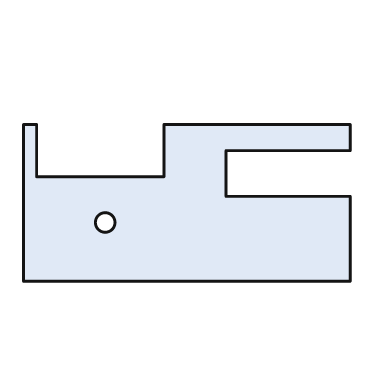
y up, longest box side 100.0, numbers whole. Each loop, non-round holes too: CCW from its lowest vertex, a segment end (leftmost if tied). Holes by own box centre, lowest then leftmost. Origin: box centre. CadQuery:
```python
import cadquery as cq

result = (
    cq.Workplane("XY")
    .moveTo(-50.0, -24.0)
    .lineTo(50.0, -24.0)
    .lineTo(50.0, 2.0)
    .lineTo(12.0, 2.0)
    .lineTo(12.0, 16.0)
    .lineTo(50.0, 16.0)
    .lineTo(50.0, 24.0)
    .lineTo(-7.0, 24.0)
    .lineTo(-7.0, 8.0)
    .lineTo(-46.0, 8.0)
    .lineTo(-46.0, 24.0)
    .lineTo(-50.0, 24.0)
    .close()
    .moveTo(-25.0, -6.0)
    .circle(3.0)
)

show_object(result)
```